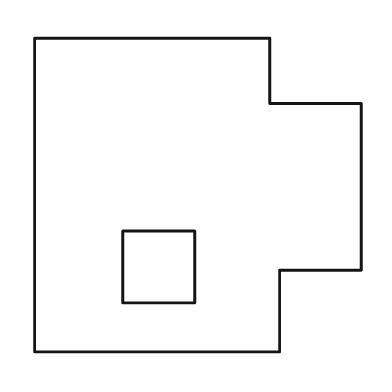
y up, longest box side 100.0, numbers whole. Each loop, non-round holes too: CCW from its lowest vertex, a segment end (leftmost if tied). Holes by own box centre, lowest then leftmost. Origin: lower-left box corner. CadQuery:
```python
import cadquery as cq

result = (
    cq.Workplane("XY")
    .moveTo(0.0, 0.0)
    .lineTo(75.0, 0.0)
    .lineTo(75.0, 25.0)
    .lineTo(100.0, 25.0)
    .lineTo(100.0, 76.0)
    .lineTo(72.0, 76.0)
    .lineTo(72.0, 96.0)
    .lineTo(0.0, 96.0)
    .close()
    .moveTo(27.0, 15.0)
    .lineTo(49.0, 15.0)
    .lineTo(49.0, 37.0)
    .lineTo(27.0, 37.0)
    .close()
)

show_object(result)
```